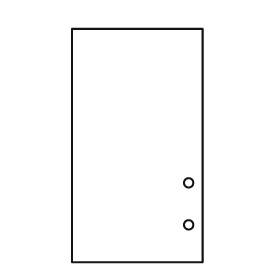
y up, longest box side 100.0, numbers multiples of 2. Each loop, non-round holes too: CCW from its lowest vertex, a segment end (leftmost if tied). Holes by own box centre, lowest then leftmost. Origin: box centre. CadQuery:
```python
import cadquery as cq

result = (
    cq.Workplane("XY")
    .moveTo(-28.0, -50.0)
    .lineTo(28.0, -50.0)
    .lineTo(28.0, 50.0)
    .lineTo(-28.0, 50.0)
    .close()
    .moveTo(22.0, -34.0)
    .circle(2.0)
    .moveTo(22.0, -16.0)
    .circle(2.0)
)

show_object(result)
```